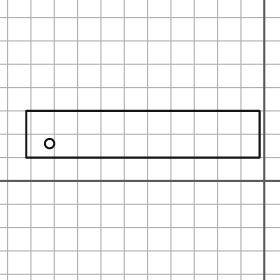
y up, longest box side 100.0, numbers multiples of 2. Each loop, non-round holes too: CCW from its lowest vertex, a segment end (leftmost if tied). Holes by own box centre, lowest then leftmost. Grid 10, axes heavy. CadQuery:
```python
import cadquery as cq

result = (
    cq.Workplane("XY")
    .moveTo(-102.0, 10.0)
    .lineTo(-2.0, 10.0)
    .lineTo(-2.0, 30.0)
    .lineTo(-102.0, 30.0)
    .close()
    .moveTo(-92.0, 16.0)
    .circle(2.0)
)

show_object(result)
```